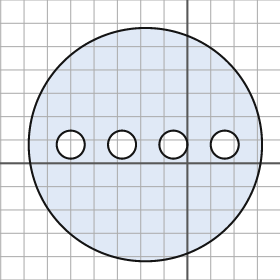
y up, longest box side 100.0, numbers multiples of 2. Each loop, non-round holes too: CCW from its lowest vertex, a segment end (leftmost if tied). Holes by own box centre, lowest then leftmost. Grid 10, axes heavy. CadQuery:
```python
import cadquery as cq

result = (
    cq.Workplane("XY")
    .moveTo(-18.0, 8.0)
    .circle(50.0)
    .moveTo(-50.0, 8.0)
    .circle(6.0)
    .moveTo(-28.0, 8.0)
    .circle(6.0)
    .moveTo(-6.0, 8.0)
    .circle(6.0)
    .moveTo(16.0, 8.0)
    .circle(6.0)
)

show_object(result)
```